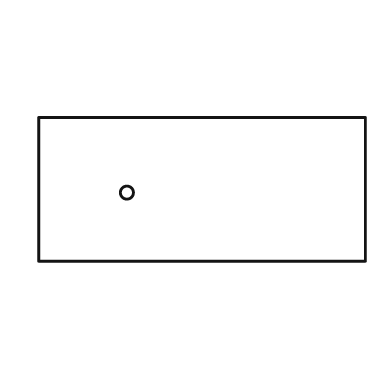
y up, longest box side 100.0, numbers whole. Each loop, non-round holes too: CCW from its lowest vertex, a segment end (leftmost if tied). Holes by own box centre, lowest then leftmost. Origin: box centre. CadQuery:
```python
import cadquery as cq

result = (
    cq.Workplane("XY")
    .moveTo(-50.0, -22.0)
    .lineTo(50.0, -22.0)
    .lineTo(50.0, 22.0)
    .lineTo(-50.0, 22.0)
    .close()
    .moveTo(-23.0, -1.0)
    .circle(2.0)
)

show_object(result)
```